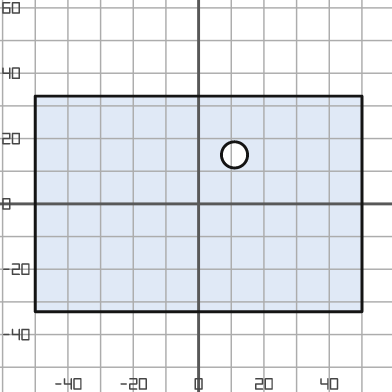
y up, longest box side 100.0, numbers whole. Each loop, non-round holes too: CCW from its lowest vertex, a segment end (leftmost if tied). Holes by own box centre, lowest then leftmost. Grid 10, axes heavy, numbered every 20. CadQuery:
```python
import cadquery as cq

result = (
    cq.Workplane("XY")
    .moveTo(-50.0, -33.0)
    .lineTo(50.0, -33.0)
    .lineTo(50.0, 33.0)
    .lineTo(-50.0, 33.0)
    .close()
    .moveTo(11.0, 15.0)
    .circle(4.0)
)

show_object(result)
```